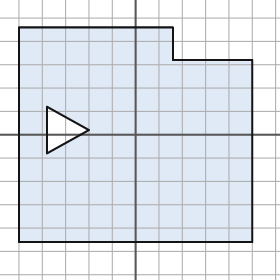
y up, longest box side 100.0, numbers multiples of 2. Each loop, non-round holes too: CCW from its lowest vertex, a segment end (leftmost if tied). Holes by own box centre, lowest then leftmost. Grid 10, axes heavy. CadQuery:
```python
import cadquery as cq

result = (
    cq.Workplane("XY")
    .moveTo(-50.0, -46.0)
    .lineTo(50.0, -46.0)
    .lineTo(50.0, 32.0)
    .lineTo(16.0, 32.0)
    .lineTo(16.0, 46.0)
    .lineTo(-50.0, 46.0)
    .close()
    .moveTo(-38.0, -8.0)
    .lineTo(-20.0, 2.0)
    .lineTo(-38.0, 12.0)
    .close()
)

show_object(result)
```